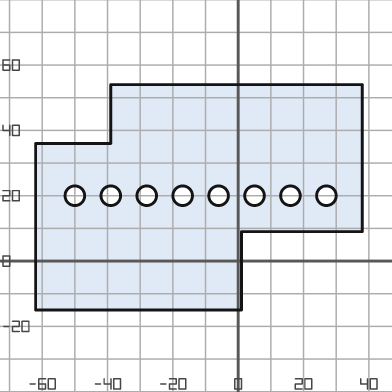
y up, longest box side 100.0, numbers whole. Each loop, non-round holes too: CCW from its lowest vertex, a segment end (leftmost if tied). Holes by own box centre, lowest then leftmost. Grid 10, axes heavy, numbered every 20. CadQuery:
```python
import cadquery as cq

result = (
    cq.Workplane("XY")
    .moveTo(-62.0, -15.0)
    .lineTo(1.0, -15.0)
    .lineTo(1.0, 9.0)
    .lineTo(38.0, 9.0)
    .lineTo(38.0, 54.0)
    .lineTo(-39.0, 54.0)
    .lineTo(-39.0, 36.0)
    .lineTo(-62.0, 36.0)
    .close()
    .moveTo(-50.0, 20.0)
    .circle(3.0)
    .moveTo(-39.0, 20.0)
    .circle(3.0)
    .moveTo(-28.0, 20.0)
    .circle(3.0)
    .moveTo(-17.0, 20.0)
    .circle(3.0)
    .moveTo(-6.0, 20.0)
    .circle(3.0)
    .moveTo(5.0, 20.0)
    .circle(3.0)
    .moveTo(16.0, 20.0)
    .circle(3.0)
    .moveTo(27.0, 20.0)
    .circle(3.0)
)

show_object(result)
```